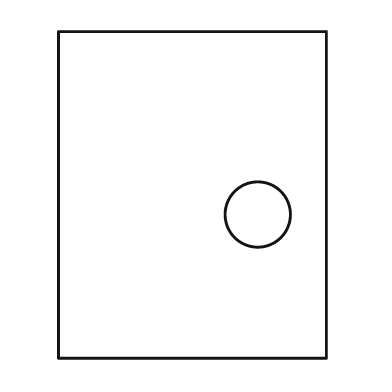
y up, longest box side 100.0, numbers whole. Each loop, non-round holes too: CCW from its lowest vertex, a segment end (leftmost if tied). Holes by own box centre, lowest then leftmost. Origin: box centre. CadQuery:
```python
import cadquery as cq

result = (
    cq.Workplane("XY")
    .moveTo(-41.0, -50.0)
    .lineTo(41.0, -50.0)
    .lineTo(41.0, 50.0)
    .lineTo(-41.0, 50.0)
    .close()
    .moveTo(20.0, -6.0)
    .circle(10.0)
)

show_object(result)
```